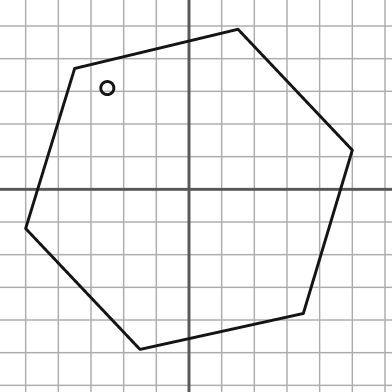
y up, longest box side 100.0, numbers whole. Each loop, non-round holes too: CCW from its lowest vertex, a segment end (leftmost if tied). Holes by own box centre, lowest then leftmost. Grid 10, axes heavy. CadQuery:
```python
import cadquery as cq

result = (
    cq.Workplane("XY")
    .moveTo(-15.0, -49.0)
    .lineTo(35.0, -38.0)
    .lineTo(50.0, 12.0)
    .lineTo(15.0, 49.0)
    .lineTo(-35.0, 37.0)
    .lineTo(-50.0, -12.0)
    .close()
    .moveTo(-25.0, 31.0)
    .circle(2.0)
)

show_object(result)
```